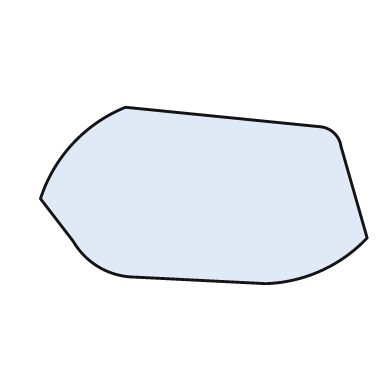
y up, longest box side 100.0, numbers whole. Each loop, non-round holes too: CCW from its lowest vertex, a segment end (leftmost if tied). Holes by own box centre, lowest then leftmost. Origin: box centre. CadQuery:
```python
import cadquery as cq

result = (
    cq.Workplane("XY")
    .moveTo(19.0, -27.0)
    .threePointArc((36.0, -23.0), (50.0, -13.0))
    .lineTo(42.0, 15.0)
    .threePointArc((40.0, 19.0), (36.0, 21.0))
    .lineTo(-24.0, 27.0)
    .threePointArc((-40.0, 16.0), (-50.0, -1.0))
    .lineTo(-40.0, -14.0)
    .threePointArc((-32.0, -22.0), (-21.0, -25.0))
    .close()
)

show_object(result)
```